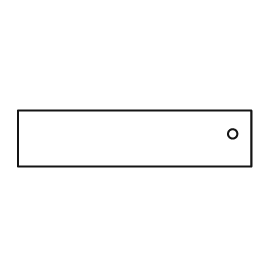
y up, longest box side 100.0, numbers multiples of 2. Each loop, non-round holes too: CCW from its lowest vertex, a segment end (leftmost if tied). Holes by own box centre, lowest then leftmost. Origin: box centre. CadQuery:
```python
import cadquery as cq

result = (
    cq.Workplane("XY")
    .moveTo(-50.0, -12.0)
    .lineTo(50.0, -12.0)
    .lineTo(50.0, 12.0)
    .lineTo(-50.0, 12.0)
    .close()
    .moveTo(42.0, 2.0)
    .circle(2.0)
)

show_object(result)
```